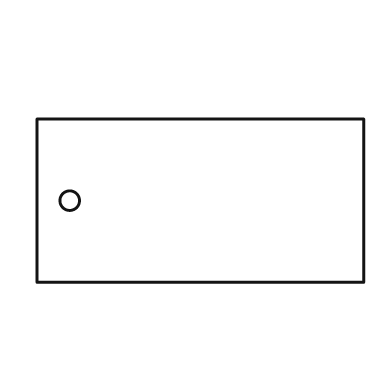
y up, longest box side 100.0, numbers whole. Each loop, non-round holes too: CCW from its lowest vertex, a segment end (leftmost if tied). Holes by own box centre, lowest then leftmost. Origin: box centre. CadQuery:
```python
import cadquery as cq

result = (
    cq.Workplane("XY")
    .moveTo(-50.0, -25.0)
    .lineTo(50.0, -25.0)
    .lineTo(50.0, 25.0)
    .lineTo(-50.0, 25.0)
    .close()
    .moveTo(-40.0, 0.0)
    .circle(3.0)
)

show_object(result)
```